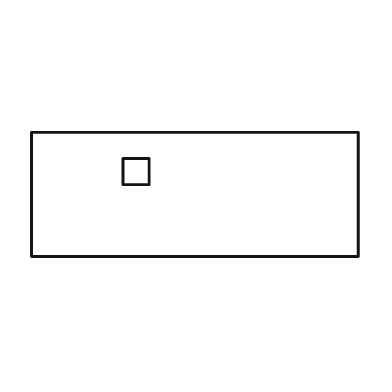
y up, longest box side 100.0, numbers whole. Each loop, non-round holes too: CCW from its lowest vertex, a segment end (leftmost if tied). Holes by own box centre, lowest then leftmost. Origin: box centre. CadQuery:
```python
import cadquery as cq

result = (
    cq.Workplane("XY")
    .moveTo(-50.0, -19.0)
    .lineTo(50.0, -19.0)
    .lineTo(50.0, 19.0)
    .lineTo(-50.0, 19.0)
    .close()
    .moveTo(-22.0, 3.0)
    .lineTo(-14.0, 3.0)
    .lineTo(-14.0, 11.0)
    .lineTo(-22.0, 11.0)
    .close()
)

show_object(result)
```